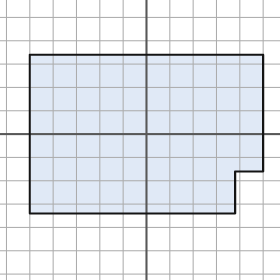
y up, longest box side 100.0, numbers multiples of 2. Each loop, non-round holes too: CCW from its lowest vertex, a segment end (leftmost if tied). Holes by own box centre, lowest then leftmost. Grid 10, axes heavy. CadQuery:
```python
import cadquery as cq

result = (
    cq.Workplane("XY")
    .moveTo(-50.0, -34.0)
    .lineTo(38.0, -34.0)
    .lineTo(38.0, -16.0)
    .lineTo(50.0, -16.0)
    .lineTo(50.0, 34.0)
    .lineTo(-50.0, 34.0)
    .close()
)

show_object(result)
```